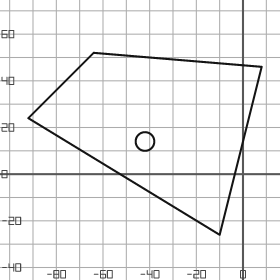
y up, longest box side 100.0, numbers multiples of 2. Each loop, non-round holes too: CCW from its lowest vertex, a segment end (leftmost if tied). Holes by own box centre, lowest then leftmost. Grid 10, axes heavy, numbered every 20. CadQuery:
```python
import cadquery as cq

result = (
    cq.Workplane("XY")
    .moveTo(-10.0, -26.0)
    .lineTo(8.0, 46.0)
    .lineTo(-64.0, 52.0)
    .lineTo(-92.0, 24.0)
    .close()
    .moveTo(-42.0, 14.0)
    .circle(4.0)
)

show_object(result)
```